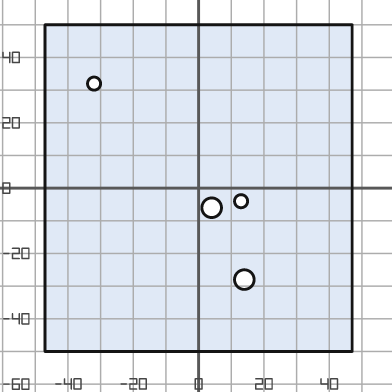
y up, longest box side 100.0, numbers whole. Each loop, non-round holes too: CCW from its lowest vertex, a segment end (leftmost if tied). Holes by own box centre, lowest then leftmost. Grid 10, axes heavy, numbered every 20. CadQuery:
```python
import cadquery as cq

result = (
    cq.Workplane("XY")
    .moveTo(-47.0, -50.0)
    .lineTo(47.0, -50.0)
    .lineTo(47.0, 50.0)
    .lineTo(-47.0, 50.0)
    .close()
    .moveTo(14.0, -28.0)
    .circle(3.0)
    .moveTo(4.0, -6.0)
    .circle(3.0)
    .moveTo(13.0, -4.0)
    .circle(2.0)
    .moveTo(-32.0, 32.0)
    .circle(2.0)
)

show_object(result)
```